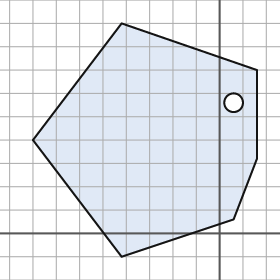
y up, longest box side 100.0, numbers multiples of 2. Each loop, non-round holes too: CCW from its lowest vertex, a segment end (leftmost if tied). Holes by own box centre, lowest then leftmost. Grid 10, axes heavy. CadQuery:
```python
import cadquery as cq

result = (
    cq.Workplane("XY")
    .moveTo(-42.0, -10.0)
    .lineTo(6.0, 6.0)
    .lineTo(16.0, 32.0)
    .lineTo(16.0, 70.0)
    .lineTo(-42.0, 90.0)
    .lineTo(-80.0, 40.0)
    .close()
    .moveTo(6.0, 56.0)
    .circle(4.0)
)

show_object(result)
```